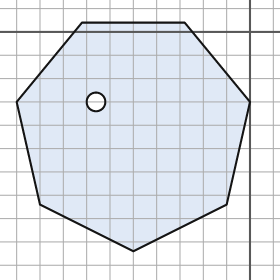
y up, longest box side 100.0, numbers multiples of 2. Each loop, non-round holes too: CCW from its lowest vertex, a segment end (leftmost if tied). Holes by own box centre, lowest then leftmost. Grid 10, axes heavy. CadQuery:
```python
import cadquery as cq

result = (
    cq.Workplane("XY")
    .moveTo(-50.0, -94.0)
    .lineTo(-10.0, -74.0)
    .lineTo(0.0, -30.0)
    .lineTo(-28.0, 4.0)
    .lineTo(-72.0, 4.0)
    .lineTo(-100.0, -30.0)
    .lineTo(-90.0, -74.0)
    .close()
    .moveTo(-66.0, -30.0)
    .circle(4.0)
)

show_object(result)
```